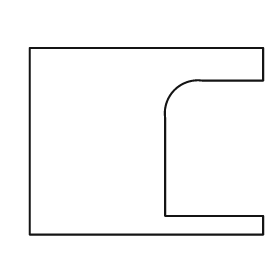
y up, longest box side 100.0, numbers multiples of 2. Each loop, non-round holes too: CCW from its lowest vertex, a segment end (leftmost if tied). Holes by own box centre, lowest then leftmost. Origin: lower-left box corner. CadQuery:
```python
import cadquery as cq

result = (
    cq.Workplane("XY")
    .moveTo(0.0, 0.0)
    .lineTo(100.0, 0.0)
    .lineTo(100.0, 8.0)
    .lineTo(58.0, 8.0)
    .lineTo(58.0, 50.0)
    .threePointArc((62.0, 62.0), (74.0, 66.0))
    .lineTo(100.0, 66.0)
    .lineTo(100.0, 80.0)
    .lineTo(0.0, 80.0)
    .close()
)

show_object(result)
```